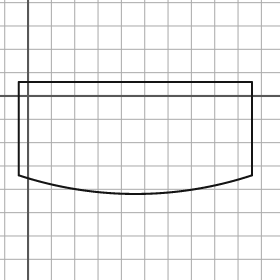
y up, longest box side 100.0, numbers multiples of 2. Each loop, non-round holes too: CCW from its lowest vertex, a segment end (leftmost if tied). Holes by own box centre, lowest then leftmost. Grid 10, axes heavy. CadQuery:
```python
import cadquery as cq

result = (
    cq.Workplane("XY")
    .moveTo(-4.0, -34.0)
    .threePointArc((46.0, -42.0), (96.0, -34.0))
    .lineTo(96.0, 6.0)
    .lineTo(-4.0, 6.0)
    .close()
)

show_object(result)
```